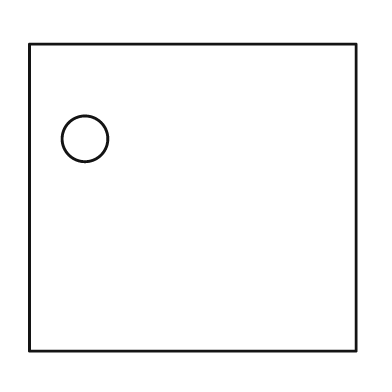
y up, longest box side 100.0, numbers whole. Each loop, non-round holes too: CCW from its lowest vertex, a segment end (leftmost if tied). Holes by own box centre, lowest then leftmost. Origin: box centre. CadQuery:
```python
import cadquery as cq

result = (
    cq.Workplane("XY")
    .moveTo(-50.0, -47.0)
    .lineTo(50.0, -47.0)
    .lineTo(50.0, 47.0)
    .lineTo(-50.0, 47.0)
    .close()
    .moveTo(-33.0, 18.0)
    .circle(7.0)
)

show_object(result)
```